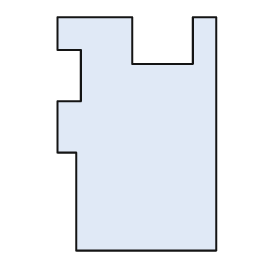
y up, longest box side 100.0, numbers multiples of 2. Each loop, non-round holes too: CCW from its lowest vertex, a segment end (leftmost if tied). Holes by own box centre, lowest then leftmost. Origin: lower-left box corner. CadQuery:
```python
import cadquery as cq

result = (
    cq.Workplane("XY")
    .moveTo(8.0, 0.0)
    .lineTo(68.0, 0.0)
    .lineTo(68.0, 100.0)
    .lineTo(58.0, 100.0)
    .lineTo(58.0, 80.0)
    .lineTo(32.0, 80.0)
    .lineTo(32.0, 100.0)
    .lineTo(0.0, 100.0)
    .lineTo(0.0, 86.0)
    .lineTo(10.0, 86.0)
    .lineTo(10.0, 64.0)
    .lineTo(0.0, 64.0)
    .lineTo(0.0, 42.0)
    .lineTo(8.0, 42.0)
    .close()
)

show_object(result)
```